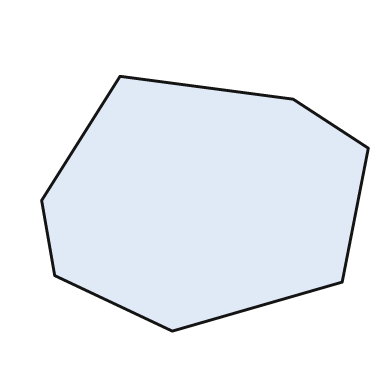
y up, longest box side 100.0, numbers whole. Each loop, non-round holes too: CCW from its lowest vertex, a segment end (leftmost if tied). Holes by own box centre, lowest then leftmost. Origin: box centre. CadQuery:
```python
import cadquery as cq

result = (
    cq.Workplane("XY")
    .moveTo(-10.0, -39.0)
    .lineTo(42.0, -24.0)
    .lineTo(50.0, 17.0)
    .lineTo(27.0, 32.0)
    .lineTo(-26.0, 39.0)
    .lineTo(-50.0, 1.0)
    .lineTo(-46.0, -22.0)
    .close()
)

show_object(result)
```